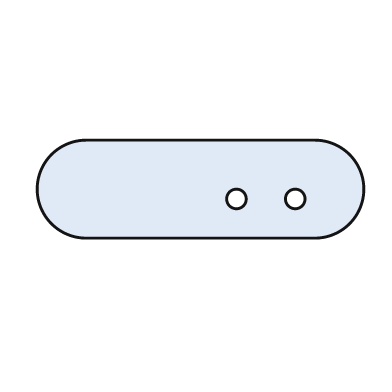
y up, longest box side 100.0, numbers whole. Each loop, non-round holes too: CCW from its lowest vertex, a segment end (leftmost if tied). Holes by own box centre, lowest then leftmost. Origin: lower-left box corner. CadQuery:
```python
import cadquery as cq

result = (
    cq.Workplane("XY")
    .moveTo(15.0, 0.0)
    .lineTo(85.0, 0.0)
    .threePointArc((100.0, 15.0), (85.0, 30.0))
    .lineTo(15.0, 30.0)
    .threePointArc((0.0, 15.0), (15.0, 0.0))
    .close()
    .moveTo(61.0, 12.0)
    .circle(3.0)
    .moveTo(79.0, 12.0)
    .circle(3.0)
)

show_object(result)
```